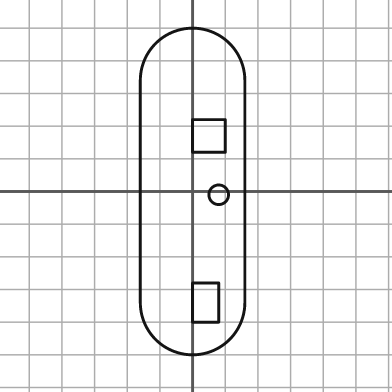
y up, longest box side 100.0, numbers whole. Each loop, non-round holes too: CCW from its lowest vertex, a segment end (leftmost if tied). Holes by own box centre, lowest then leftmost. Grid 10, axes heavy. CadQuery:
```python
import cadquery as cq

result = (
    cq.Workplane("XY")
    .moveTo(-16.0, -34.0)
    .threePointArc((0.0, -50.0), (16.0, -34.0))
    .lineTo(16.0, 34.0)
    .threePointArc((0.0, 50.0), (-16.0, 34.0))
    .close()
    .moveTo(0.0, -40.0)
    .lineTo(8.0, -40.0)
    .lineTo(8.0, -28.0)
    .lineTo(0.0, -28.0)
    .close()
    .moveTo(8.0, -1.0)
    .circle(3.0)
    .moveTo(0.0, 12.0)
    .lineTo(10.0, 12.0)
    .lineTo(10.0, 22.0)
    .lineTo(0.0, 22.0)
    .close()
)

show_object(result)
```